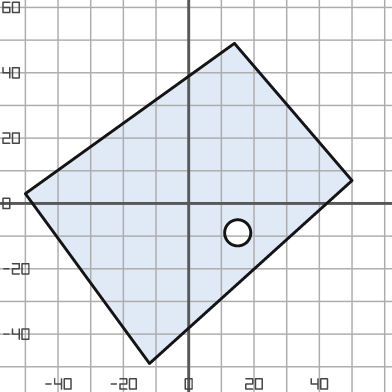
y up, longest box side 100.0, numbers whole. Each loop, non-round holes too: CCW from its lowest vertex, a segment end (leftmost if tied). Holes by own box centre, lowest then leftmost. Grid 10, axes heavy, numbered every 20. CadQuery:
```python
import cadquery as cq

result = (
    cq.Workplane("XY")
    .moveTo(-12.0, -49.0)
    .lineTo(50.0, 7.0)
    .lineTo(14.0, 49.0)
    .lineTo(-50.0, 3.0)
    .close()
    .moveTo(15.0, -9.0)
    .circle(4.0)
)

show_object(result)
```